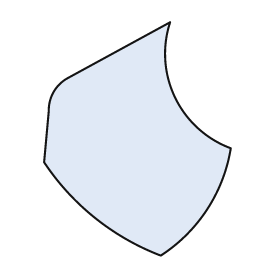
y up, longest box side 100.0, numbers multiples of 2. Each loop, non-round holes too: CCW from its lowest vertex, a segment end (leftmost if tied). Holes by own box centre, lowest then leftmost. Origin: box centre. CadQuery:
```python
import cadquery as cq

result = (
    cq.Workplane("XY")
    .moveTo(10.0, -50.0)
    .threePointArc((30.0, -30.0), (40.0, -4.0))
    .threePointArc((16.0, 18.0), (14.0, 50.0))
    .lineTo(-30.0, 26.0)
    .threePointArc((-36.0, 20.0), (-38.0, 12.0))
    .lineTo(-40.0, -10.0)
    .threePointArc((-18.0, -34.0), (10.0, -50.0))
    .close()
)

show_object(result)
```